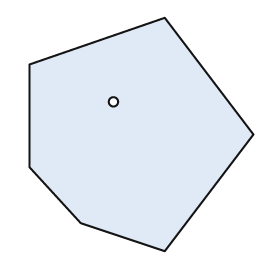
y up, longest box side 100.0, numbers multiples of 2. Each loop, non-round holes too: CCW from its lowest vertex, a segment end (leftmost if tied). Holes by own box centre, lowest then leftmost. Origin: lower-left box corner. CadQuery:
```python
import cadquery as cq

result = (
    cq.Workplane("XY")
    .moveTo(58.0, 0.0)
    .lineTo(96.0, 50.0)
    .lineTo(58.0, 100.0)
    .lineTo(0.0, 80.0)
    .lineTo(0.0, 36.0)
    .lineTo(22.0, 12.0)
    .close()
    .moveTo(36.0, 64.0)
    .circle(2.0)
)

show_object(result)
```